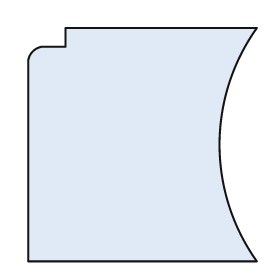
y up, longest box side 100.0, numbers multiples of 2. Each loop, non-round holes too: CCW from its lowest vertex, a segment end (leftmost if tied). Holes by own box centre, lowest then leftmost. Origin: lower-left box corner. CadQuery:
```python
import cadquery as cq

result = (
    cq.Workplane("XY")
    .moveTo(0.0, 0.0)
    .lineTo(98.0, 0.0)
    .threePointArc((82.0, 50.0), (98.0, 100.0))
    .lineTo(16.0, 100.0)
    .lineTo(16.0, 92.0)
    .lineTo(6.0, 92.0)
    .threePointArc((2.0, 90.0), (0.0, 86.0))
    .close()
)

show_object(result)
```